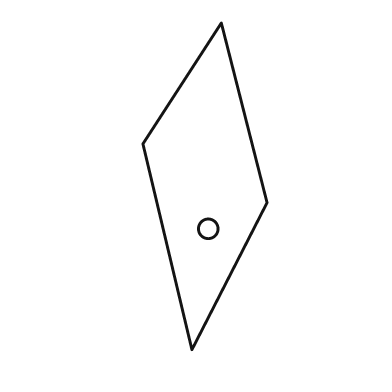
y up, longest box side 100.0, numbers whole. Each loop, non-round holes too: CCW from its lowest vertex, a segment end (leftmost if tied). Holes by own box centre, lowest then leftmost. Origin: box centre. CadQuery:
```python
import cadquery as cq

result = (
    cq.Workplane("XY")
    .moveTo(-4.0, -50.0)
    .lineTo(19.0, -5.0)
    .lineTo(5.0, 50.0)
    .lineTo(-19.0, 13.0)
    .close()
    .moveTo(1.0, -13.0)
    .circle(3.0)
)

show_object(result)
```